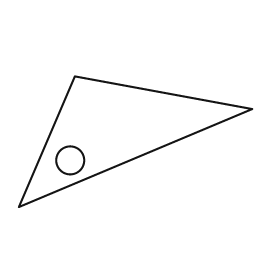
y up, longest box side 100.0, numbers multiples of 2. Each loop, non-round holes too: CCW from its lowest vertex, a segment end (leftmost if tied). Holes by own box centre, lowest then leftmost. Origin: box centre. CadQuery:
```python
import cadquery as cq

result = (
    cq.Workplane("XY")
    .moveTo(-50.0, -28.0)
    .lineTo(50.0, 14.0)
    .lineTo(-26.0, 28.0)
    .close()
    .moveTo(-28.0, -8.0)
    .circle(6.0)
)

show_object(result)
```